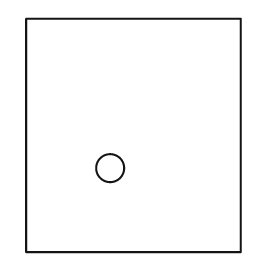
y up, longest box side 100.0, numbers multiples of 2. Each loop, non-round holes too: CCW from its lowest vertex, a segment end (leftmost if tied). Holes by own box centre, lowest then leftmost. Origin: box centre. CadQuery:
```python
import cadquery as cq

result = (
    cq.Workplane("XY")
    .moveTo(-46.0, -50.0)
    .lineTo(46.0, -50.0)
    .lineTo(46.0, 50.0)
    .lineTo(-46.0, 50.0)
    .close()
    .moveTo(-10.0, -14.0)
    .circle(6.0)
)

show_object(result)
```